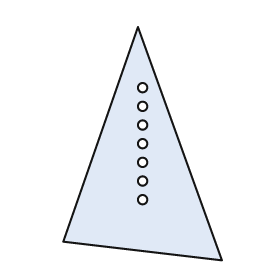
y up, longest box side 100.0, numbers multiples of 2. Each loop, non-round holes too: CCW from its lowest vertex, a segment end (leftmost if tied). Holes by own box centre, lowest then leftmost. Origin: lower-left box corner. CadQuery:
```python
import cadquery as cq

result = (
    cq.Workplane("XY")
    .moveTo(68.0, 0.0)
    .lineTo(32.0, 100.0)
    .lineTo(0.0, 8.0)
    .close()
    .moveTo(34.0, 26.0)
    .circle(2.0)
    .moveTo(34.0, 34.0)
    .circle(2.0)
    .moveTo(34.0, 42.0)
    .circle(2.0)
    .moveTo(34.0, 50.0)
    .circle(2.0)
    .moveTo(34.0, 58.0)
    .circle(2.0)
    .moveTo(34.0, 66.0)
    .circle(2.0)
    .moveTo(34.0, 74.0)
    .circle(2.0)
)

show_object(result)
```